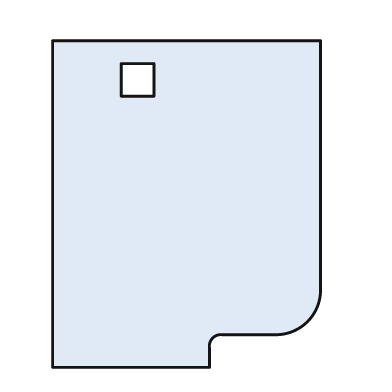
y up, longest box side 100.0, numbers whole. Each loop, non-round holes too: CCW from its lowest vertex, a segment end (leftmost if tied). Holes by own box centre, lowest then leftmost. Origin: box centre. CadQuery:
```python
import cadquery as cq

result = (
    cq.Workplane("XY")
    .moveTo(-41.0, -50.0)
    .lineTo(7.0, -50.0)
    .lineTo(7.0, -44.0)
    .threePointArc((8.0, -41.0), (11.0, -40.0))
    .lineTo(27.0, -40.0)
    .threePointArc((37.0, -36.0), (41.0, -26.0))
    .lineTo(41.0, 50.0)
    .lineTo(-41.0, 50.0)
    .close()
    .moveTo(-20.0, 33.0)
    .lineTo(-10.0, 33.0)
    .lineTo(-10.0, 43.0)
    .lineTo(-20.0, 43.0)
    .close()
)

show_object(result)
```